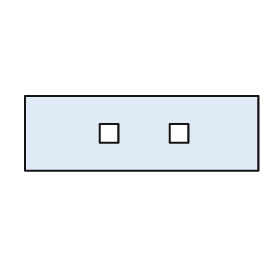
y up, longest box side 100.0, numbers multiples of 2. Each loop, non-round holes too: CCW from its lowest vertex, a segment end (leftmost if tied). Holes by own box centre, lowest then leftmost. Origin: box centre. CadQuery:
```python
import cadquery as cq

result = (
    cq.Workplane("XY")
    .moveTo(-50.0, -16.0)
    .lineTo(50.0, -16.0)
    .lineTo(50.0, 16.0)
    .lineTo(-50.0, 16.0)
    .close()
    .moveTo(-18.0, -4.0)
    .lineTo(-10.0, -4.0)
    .lineTo(-10.0, 4.0)
    .lineTo(-18.0, 4.0)
    .close()
    .moveTo(12.0, -4.0)
    .lineTo(20.0, -4.0)
    .lineTo(20.0, 4.0)
    .lineTo(12.0, 4.0)
    .close()
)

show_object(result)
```